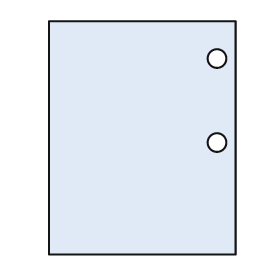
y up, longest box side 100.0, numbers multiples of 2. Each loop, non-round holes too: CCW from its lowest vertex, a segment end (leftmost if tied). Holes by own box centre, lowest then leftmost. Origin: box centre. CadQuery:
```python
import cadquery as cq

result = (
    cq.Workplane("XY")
    .moveTo(-40.0, -50.0)
    .lineTo(40.0, -50.0)
    .lineTo(40.0, 50.0)
    .lineTo(-40.0, 50.0)
    .close()
    .moveTo(32.0, -2.0)
    .circle(4.0)
    .moveTo(32.0, 34.0)
    .circle(4.0)
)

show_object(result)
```